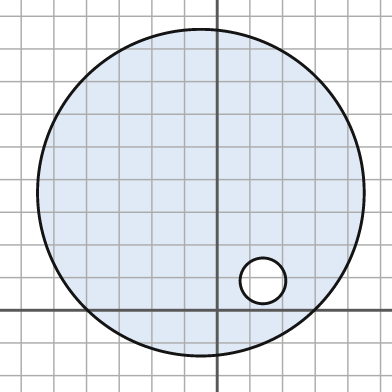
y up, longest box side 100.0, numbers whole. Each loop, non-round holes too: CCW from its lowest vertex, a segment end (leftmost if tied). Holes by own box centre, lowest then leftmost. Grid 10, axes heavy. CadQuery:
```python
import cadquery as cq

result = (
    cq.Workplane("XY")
    .moveTo(-5.0, 36.0)
    .circle(50.0)
    .moveTo(14.0, 9.0)
    .circle(7.0)
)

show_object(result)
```